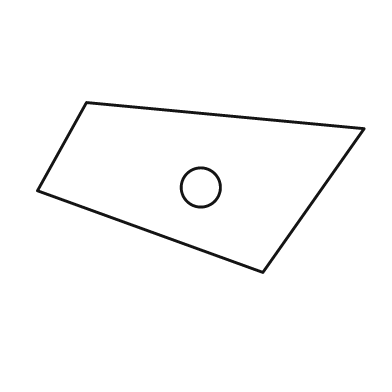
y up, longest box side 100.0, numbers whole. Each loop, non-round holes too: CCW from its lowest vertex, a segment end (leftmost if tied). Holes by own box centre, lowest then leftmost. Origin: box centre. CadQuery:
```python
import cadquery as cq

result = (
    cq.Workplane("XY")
    .moveTo(19.0, -26.0)
    .lineTo(50.0, 18.0)
    .lineTo(-35.0, 26.0)
    .lineTo(-50.0, -1.0)
    .close()
    .moveTo(0.0, 0.0)
    .circle(6.0)
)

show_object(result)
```